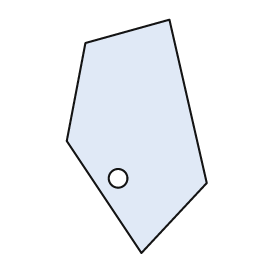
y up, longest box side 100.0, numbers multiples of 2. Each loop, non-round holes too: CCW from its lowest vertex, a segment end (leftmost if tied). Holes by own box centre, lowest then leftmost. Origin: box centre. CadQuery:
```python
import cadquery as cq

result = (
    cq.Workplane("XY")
    .moveTo(2.0, -50.0)
    .lineTo(30.0, -20.0)
    .lineTo(14.0, 50.0)
    .lineTo(-22.0, 40.0)
    .lineTo(-30.0, -2.0)
    .close()
    .moveTo(-8.0, -18.0)
    .circle(4.0)
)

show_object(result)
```